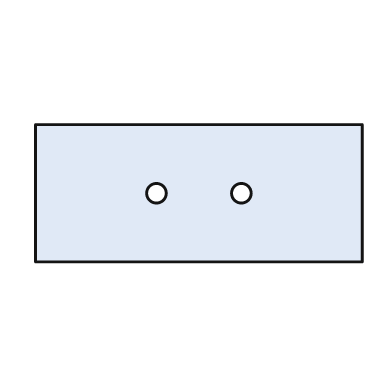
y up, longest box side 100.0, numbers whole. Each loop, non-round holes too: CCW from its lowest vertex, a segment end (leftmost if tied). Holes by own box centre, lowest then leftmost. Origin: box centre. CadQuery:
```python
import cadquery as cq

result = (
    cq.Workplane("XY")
    .moveTo(-50.0, -21.0)
    .lineTo(50.0, -21.0)
    .lineTo(50.0, 21.0)
    .lineTo(-50.0, 21.0)
    .close()
    .moveTo(-13.0, 0.0)
    .circle(3.0)
    .moveTo(13.0, 0.0)
    .circle(3.0)
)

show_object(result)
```